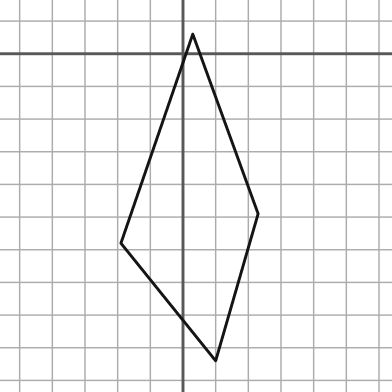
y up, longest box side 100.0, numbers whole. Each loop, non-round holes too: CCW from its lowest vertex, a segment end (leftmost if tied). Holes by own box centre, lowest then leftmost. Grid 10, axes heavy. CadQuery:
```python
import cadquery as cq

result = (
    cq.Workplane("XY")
    .moveTo(10.0, -94.0)
    .lineTo(23.0, -49.0)
    .lineTo(3.0, 6.0)
    .lineTo(-19.0, -58.0)
    .close()
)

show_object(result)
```